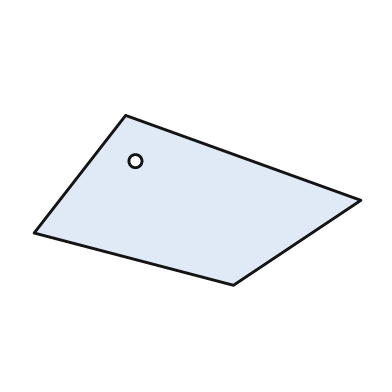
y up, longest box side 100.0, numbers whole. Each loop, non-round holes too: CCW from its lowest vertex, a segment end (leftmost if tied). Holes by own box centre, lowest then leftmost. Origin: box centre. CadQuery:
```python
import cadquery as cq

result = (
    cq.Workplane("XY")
    .moveTo(11.0, -26.0)
    .lineTo(50.0, 0.0)
    .lineTo(-22.0, 26.0)
    .lineTo(-50.0, -10.0)
    .close()
    .moveTo(-19.0, 12.0)
    .circle(2.0)
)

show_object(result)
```